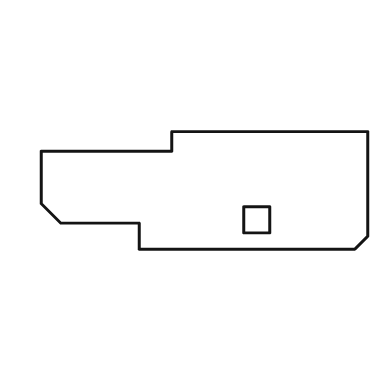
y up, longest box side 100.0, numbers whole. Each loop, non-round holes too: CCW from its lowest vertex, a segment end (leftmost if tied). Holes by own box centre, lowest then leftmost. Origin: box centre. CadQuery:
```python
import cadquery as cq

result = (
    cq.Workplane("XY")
    .moveTo(-20.0, -18.0)
    .lineTo(46.0, -18.0)
    .lineTo(50.0, -14.0)
    .lineTo(50.0, 18.0)
    .lineTo(-10.0, 18.0)
    .lineTo(-10.0, 12.0)
    .lineTo(-50.0, 12.0)
    .lineTo(-50.0, -4.0)
    .lineTo(-44.0, -10.0)
    .lineTo(-20.0, -10.0)
    .close()
    .moveTo(12.0, -13.0)
    .lineTo(20.0, -13.0)
    .lineTo(20.0, -5.0)
    .lineTo(12.0, -5.0)
    .close()
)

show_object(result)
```